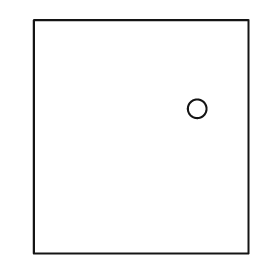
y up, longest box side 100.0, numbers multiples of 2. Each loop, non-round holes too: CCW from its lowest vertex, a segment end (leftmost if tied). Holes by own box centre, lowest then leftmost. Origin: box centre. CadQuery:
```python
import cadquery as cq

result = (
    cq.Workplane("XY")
    .moveTo(-46.0, -50.0)
    .lineTo(46.0, -50.0)
    .lineTo(46.0, 50.0)
    .lineTo(-46.0, 50.0)
    .close()
    .moveTo(24.0, 12.0)
    .circle(4.0)
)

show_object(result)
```